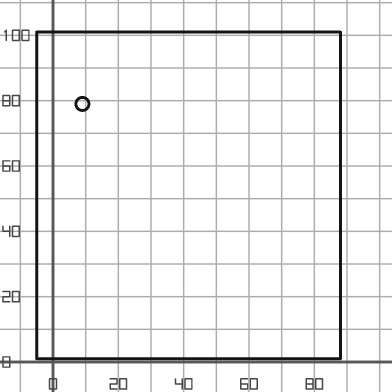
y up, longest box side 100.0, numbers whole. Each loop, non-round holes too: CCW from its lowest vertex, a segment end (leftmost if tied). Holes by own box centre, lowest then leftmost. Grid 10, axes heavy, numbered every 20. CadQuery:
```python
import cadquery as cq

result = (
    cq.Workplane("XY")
    .moveTo(-5.0, 1.0)
    .lineTo(88.0, 1.0)
    .lineTo(88.0, 101.0)
    .lineTo(-5.0, 101.0)
    .close()
    .moveTo(9.0, 79.0)
    .circle(2.0)
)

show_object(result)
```